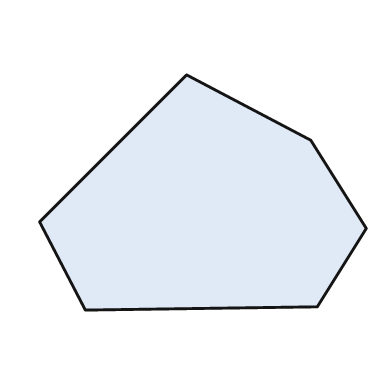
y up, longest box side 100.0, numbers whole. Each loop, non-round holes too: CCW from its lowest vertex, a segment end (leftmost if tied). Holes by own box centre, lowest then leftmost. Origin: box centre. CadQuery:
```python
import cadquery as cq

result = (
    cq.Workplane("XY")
    .moveTo(-36.0, -36.0)
    .lineTo(35.0, -35.0)
    .lineTo(50.0, -11.0)
    .lineTo(33.0, 16.0)
    .lineTo(-5.0, 36.0)
    .lineTo(-50.0, -9.0)
    .close()
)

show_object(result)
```